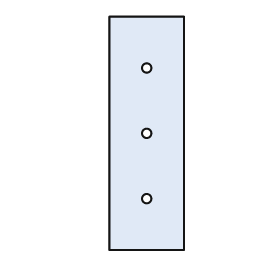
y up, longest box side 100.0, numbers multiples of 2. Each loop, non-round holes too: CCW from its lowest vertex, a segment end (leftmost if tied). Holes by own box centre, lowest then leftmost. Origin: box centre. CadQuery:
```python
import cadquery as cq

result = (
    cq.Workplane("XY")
    .moveTo(-16.0, -50.0)
    .lineTo(16.0, -50.0)
    .lineTo(16.0, 50.0)
    .lineTo(-16.0, 50.0)
    .close()
    .moveTo(0.0, -28.0)
    .circle(2.0)
    .moveTo(0.0, 0.0)
    .circle(2.0)
    .moveTo(0.0, 28.0)
    .circle(2.0)
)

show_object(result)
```